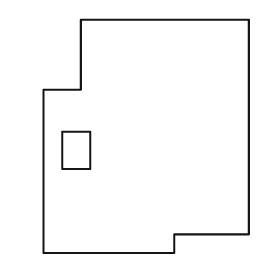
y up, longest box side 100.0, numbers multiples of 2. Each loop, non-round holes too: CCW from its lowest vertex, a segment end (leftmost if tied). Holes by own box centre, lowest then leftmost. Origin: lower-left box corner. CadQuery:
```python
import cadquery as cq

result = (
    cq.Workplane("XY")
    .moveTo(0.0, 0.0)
    .lineTo(56.0, 0.0)
    .lineTo(56.0, 8.0)
    .lineTo(88.0, 8.0)
    .lineTo(88.0, 100.0)
    .lineTo(16.0, 100.0)
    .lineTo(16.0, 70.0)
    .lineTo(0.0, 70.0)
    .close()
    .moveTo(8.0, 36.0)
    .lineTo(20.0, 36.0)
    .lineTo(20.0, 52.0)
    .lineTo(8.0, 52.0)
    .close()
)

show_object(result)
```